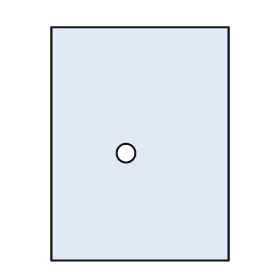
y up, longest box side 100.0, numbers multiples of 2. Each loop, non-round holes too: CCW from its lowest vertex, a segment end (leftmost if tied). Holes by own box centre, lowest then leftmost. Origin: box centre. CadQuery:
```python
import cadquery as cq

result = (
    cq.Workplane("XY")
    .moveTo(-38.0, -50.0)
    .lineTo(38.0, -50.0)
    .lineTo(38.0, 50.0)
    .lineTo(-38.0, 50.0)
    .close()
    .moveTo(-6.0, -4.0)
    .circle(4.0)
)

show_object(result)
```